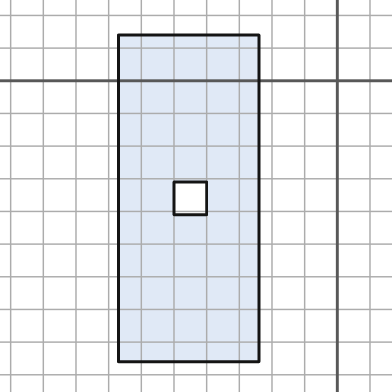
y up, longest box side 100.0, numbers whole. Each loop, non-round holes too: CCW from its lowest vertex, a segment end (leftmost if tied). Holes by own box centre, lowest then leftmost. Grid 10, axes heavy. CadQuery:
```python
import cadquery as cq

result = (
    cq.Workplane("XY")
    .moveTo(-67.0, -86.0)
    .lineTo(-24.0, -86.0)
    .lineTo(-24.0, 14.0)
    .lineTo(-67.0, 14.0)
    .close()
    .moveTo(-50.0, -41.0)
    .lineTo(-40.0, -41.0)
    .lineTo(-40.0, -31.0)
    .lineTo(-50.0, -31.0)
    .close()
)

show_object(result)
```